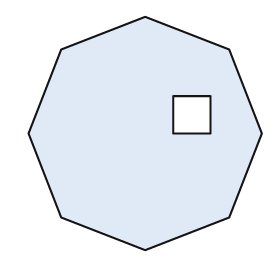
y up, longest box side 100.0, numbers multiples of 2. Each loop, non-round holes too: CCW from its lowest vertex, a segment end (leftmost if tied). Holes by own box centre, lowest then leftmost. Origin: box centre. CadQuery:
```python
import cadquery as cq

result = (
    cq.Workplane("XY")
    .moveTo(0.0, -50.0)
    .lineTo(36.0, -36.0)
    .lineTo(50.0, 0.0)
    .lineTo(36.0, 36.0)
    .lineTo(0.0, 50.0)
    .lineTo(-36.0, 36.0)
    .lineTo(-50.0, 0.0)
    .lineTo(-36.0, -36.0)
    .close()
    .moveTo(12.0, 0.0)
    .lineTo(28.0, 0.0)
    .lineTo(28.0, 16.0)
    .lineTo(12.0, 16.0)
    .close()
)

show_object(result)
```